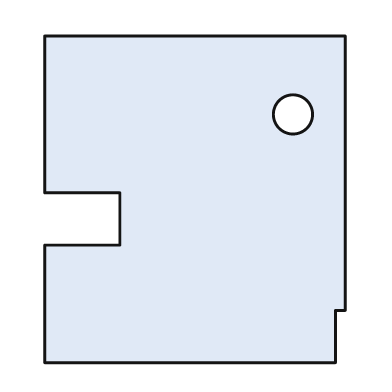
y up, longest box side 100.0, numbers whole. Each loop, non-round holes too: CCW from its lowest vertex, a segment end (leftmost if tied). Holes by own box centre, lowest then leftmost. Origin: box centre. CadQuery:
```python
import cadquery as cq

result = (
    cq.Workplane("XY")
    .moveTo(-46.0, -50.0)
    .lineTo(43.0, -50.0)
    .lineTo(43.0, -34.0)
    .lineTo(46.0, -34.0)
    .lineTo(46.0, 50.0)
    .lineTo(-46.0, 50.0)
    .lineTo(-46.0, 2.0)
    .lineTo(-23.0, 2.0)
    .lineTo(-23.0, -14.0)
    .lineTo(-46.0, -14.0)
    .close()
    .moveTo(30.0, 26.0)
    .circle(6.0)
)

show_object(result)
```